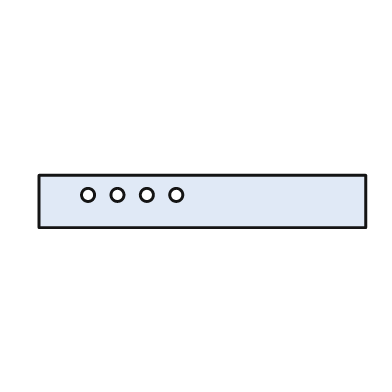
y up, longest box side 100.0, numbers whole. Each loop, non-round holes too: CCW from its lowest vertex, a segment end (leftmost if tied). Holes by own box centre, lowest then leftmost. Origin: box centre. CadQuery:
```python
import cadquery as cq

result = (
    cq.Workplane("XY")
    .moveTo(-50.0, -8.0)
    .lineTo(50.0, -8.0)
    .lineTo(50.0, 8.0)
    .lineTo(-50.0, 8.0)
    .close()
    .moveTo(-35.0, 2.0)
    .circle(2.0)
    .moveTo(-26.0, 2.0)
    .circle(2.0)
    .moveTo(-17.0, 2.0)
    .circle(2.0)
    .moveTo(-8.0, 2.0)
    .circle(2.0)
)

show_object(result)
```